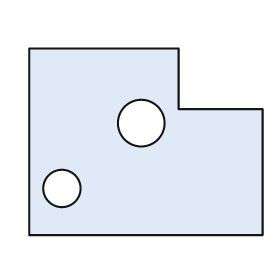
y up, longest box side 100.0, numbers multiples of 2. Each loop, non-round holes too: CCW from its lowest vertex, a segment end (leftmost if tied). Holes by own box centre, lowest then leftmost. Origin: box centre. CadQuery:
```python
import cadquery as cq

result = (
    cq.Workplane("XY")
    .moveTo(-50.0, -40.0)
    .lineTo(50.0, -40.0)
    .lineTo(50.0, 14.0)
    .lineTo(14.0, 14.0)
    .lineTo(14.0, 40.0)
    .lineTo(-50.0, 40.0)
    .close()
    .moveTo(-36.0, -20.0)
    .circle(8.0)
    .moveTo(-2.0, 8.0)
    .circle(10.0)
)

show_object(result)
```